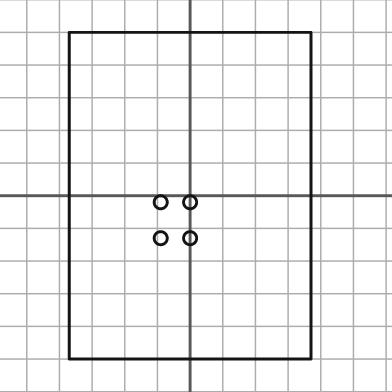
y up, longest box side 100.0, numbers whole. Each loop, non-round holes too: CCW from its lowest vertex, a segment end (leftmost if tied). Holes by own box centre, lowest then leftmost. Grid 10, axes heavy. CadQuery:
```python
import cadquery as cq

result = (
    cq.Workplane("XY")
    .moveTo(-37.0, -50.0)
    .lineTo(37.0, -50.0)
    .lineTo(37.0, 50.0)
    .lineTo(-37.0, 50.0)
    .close()
    .moveTo(-9.0, -13.0)
    .circle(2.0)
    .moveTo(0.0, -13.0)
    .circle(2.0)
    .moveTo(-9.0, -2.0)
    .circle(2.0)
    .moveTo(0.0, -2.0)
    .circle(2.0)
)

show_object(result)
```